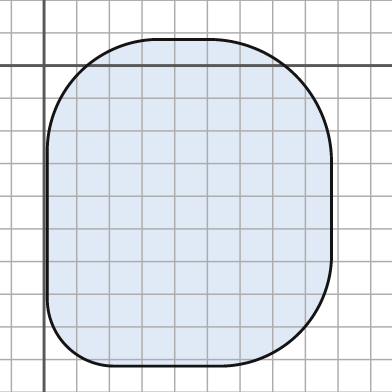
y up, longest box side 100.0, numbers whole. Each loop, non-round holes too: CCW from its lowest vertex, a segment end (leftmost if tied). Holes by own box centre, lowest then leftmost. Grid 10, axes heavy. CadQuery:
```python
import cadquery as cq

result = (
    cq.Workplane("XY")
    .moveTo(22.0, -92.0)
    .lineTo(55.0, -92.0)
    .threePointArc((78.0, -82.0), (88.0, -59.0))
    .lineTo(88.0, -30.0)
    .threePointArc((77.0, -3.0), (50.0, 8.0))
    .lineTo(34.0, 8.0)
    .threePointArc((11.0, -2.0), (1.0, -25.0))
    .lineTo(1.0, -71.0)
    .threePointArc((7.0, -86.0), (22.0, -92.0))
    .close()
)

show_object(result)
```